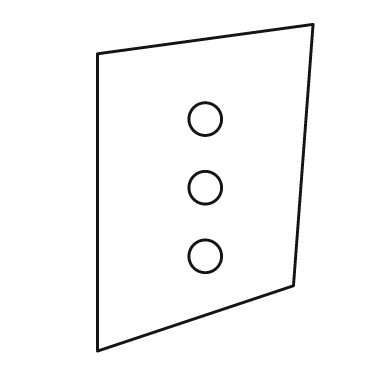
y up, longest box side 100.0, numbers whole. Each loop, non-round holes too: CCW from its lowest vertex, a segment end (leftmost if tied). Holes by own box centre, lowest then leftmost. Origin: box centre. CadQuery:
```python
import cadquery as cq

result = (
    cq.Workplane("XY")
    .moveTo(-33.0, -50.0)
    .lineTo(27.0, -30.0)
    .lineTo(33.0, 50.0)
    .lineTo(-33.0, 41.0)
    .close()
    .moveTo(0.0, -21.0)
    .circle(5.0)
    .moveTo(0.0, 0.0)
    .circle(5.0)
    .moveTo(0.0, 21.0)
    .circle(5.0)
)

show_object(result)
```